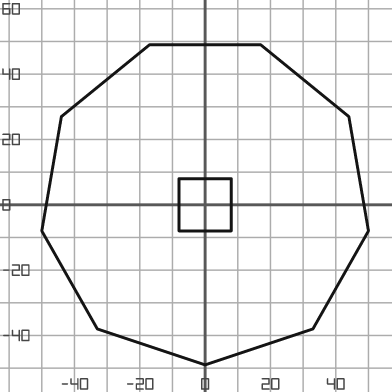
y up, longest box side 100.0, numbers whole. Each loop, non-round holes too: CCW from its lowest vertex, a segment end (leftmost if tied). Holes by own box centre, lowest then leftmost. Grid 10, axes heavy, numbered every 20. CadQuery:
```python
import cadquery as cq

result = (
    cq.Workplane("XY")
    .moveTo(0.0, -49.0)
    .lineTo(33.0, -38.0)
    .lineTo(50.0, -8.0)
    .lineTo(44.0, 27.0)
    .lineTo(17.0, 49.0)
    .lineTo(-17.0, 49.0)
    .lineTo(-44.0, 27.0)
    .lineTo(-50.0, -8.0)
    .lineTo(-33.0, -38.0)
    .close()
    .moveTo(-8.0, -8.0)
    .lineTo(8.0, -8.0)
    .lineTo(8.0, 8.0)
    .lineTo(-8.0, 8.0)
    .close()
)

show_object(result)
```